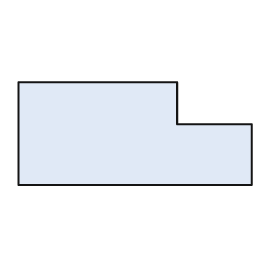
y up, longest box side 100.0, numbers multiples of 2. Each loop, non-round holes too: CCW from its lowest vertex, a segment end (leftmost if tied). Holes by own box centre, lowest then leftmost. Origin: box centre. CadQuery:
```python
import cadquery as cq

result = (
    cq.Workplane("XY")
    .moveTo(-50.0, -22.0)
    .lineTo(50.0, -22.0)
    .lineTo(50.0, 4.0)
    .lineTo(18.0, 4.0)
    .lineTo(18.0, 22.0)
    .lineTo(-50.0, 22.0)
    .close()
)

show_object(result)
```